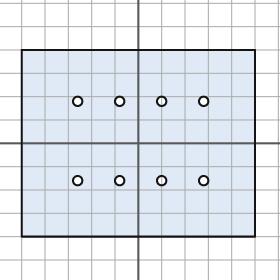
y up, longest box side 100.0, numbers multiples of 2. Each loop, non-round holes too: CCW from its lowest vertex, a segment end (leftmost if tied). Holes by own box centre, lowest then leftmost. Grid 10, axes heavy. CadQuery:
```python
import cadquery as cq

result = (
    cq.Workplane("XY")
    .moveTo(-50.0, -40.0)
    .lineTo(50.0, -40.0)
    .lineTo(50.0, 40.0)
    .lineTo(-50.0, 40.0)
    .close()
    .moveTo(-26.0, -16.0)
    .circle(2.0)
    .moveTo(-8.0, -16.0)
    .circle(2.0)
    .moveTo(10.0, -16.0)
    .circle(2.0)
    .moveTo(28.0, -16.0)
    .circle(2.0)
    .moveTo(-26.0, 18.0)
    .circle(2.0)
    .moveTo(-8.0, 18.0)
    .circle(2.0)
    .moveTo(10.0, 18.0)
    .circle(2.0)
    .moveTo(28.0, 18.0)
    .circle(2.0)
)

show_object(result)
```